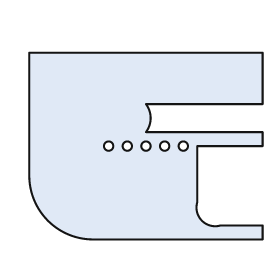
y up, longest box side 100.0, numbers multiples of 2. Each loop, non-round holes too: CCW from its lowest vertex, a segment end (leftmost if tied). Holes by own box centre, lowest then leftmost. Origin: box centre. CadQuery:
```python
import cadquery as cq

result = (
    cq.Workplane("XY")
    .moveTo(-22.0, -40.0)
    .lineTo(50.0, -40.0)
    .lineTo(50.0, -34.0)
    .lineTo(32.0, -34.0)
    .threePointArc((24.0, -32.0), (22.0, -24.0))
    .lineTo(22.0, 0.0)
    .lineTo(50.0, 0.0)
    .lineTo(50.0, 6.0)
    .lineTo(0.0, 6.0)
    .threePointArc((2.0, 12.0), (0.0, 18.0))
    .lineTo(50.0, 18.0)
    .lineTo(50.0, 40.0)
    .lineTo(-50.0, 40.0)
    .lineTo(-50.0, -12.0)
    .threePointArc((-42.0, -32.0), (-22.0, -40.0))
    .close()
    .moveTo(-16.0, 0.0)
    .circle(2.0)
    .moveTo(-8.0, 0.0)
    .circle(2.0)
    .moveTo(0.0, 0.0)
    .circle(2.0)
    .moveTo(8.0, 0.0)
    .circle(2.0)
    .moveTo(16.0, 0.0)
    .circle(2.0)
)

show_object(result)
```